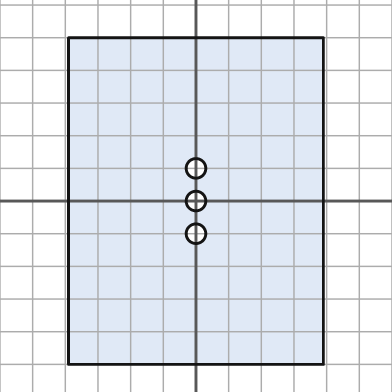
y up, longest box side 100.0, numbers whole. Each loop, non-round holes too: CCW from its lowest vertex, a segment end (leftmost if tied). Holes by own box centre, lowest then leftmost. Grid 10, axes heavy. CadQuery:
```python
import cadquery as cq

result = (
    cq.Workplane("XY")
    .moveTo(-39.0, -50.0)
    .lineTo(39.0, -50.0)
    .lineTo(39.0, 50.0)
    .lineTo(-39.0, 50.0)
    .close()
    .moveTo(0.0, -10.0)
    .circle(3.0)
    .moveTo(0.0, 0.0)
    .circle(3.0)
    .moveTo(0.0, 10.0)
    .circle(3.0)
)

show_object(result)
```